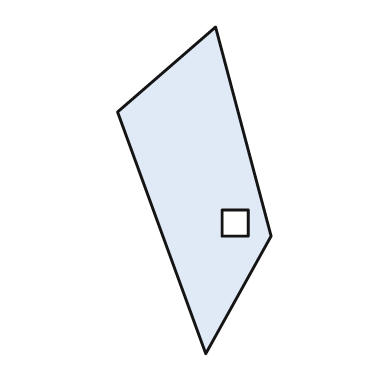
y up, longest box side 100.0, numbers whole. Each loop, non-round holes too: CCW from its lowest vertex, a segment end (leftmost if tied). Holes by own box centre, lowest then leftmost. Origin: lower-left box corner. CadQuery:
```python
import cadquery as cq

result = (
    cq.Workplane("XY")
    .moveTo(27.0, 0.0)
    .lineTo(47.0, 36.0)
    .lineTo(30.0, 100.0)
    .lineTo(0.0, 74.0)
    .close()
    .moveTo(32.0, 36.0)
    .lineTo(40.0, 36.0)
    .lineTo(40.0, 44.0)
    .lineTo(32.0, 44.0)
    .close()
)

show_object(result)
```